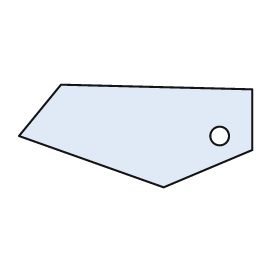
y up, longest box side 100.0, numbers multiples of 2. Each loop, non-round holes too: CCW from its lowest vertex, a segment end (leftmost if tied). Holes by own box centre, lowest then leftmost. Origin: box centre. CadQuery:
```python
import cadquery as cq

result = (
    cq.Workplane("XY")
    .moveTo(12.0, -22.0)
    .lineTo(50.0, -6.0)
    .lineTo(50.0, 20.0)
    .lineTo(-32.0, 22.0)
    .lineTo(-50.0, 0.0)
    .close()
    .moveTo(36.0, 0.0)
    .circle(4.0)
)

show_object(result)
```